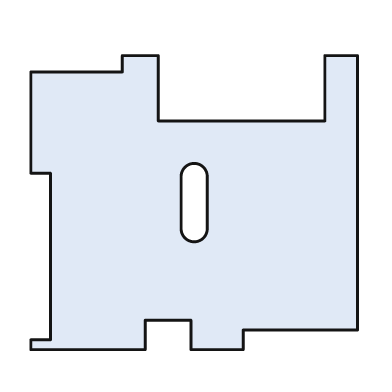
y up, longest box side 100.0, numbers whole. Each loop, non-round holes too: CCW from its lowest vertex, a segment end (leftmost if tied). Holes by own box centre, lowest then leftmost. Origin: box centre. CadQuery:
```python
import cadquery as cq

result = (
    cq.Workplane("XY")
    .moveTo(-50.0, -45.0)
    .lineTo(-15.0, -45.0)
    .lineTo(-15.0, -36.0)
    .lineTo(-1.0, -36.0)
    .lineTo(-1.0, -45.0)
    .lineTo(15.0, -45.0)
    .lineTo(15.0, -39.0)
    .lineTo(50.0, -39.0)
    .lineTo(50.0, 45.0)
    .lineTo(40.0, 45.0)
    .lineTo(40.0, 25.0)
    .lineTo(-11.0, 25.0)
    .lineTo(-11.0, 45.0)
    .lineTo(-22.0, 45.0)
    .lineTo(-22.0, 40.0)
    .lineTo(-50.0, 40.0)
    .lineTo(-50.0, 9.0)
    .lineTo(-44.0, 9.0)
    .lineTo(-44.0, -42.0)
    .lineTo(-50.0, -42.0)
    .close()
    .moveTo(-4.0, -8.0)
    .threePointArc((0.0, -12.0), (4.0, -8.0))
    .lineTo(4.0, 8.0)
    .threePointArc((0.0, 12.0), (-4.0, 8.0))
    .close()
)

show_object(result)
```